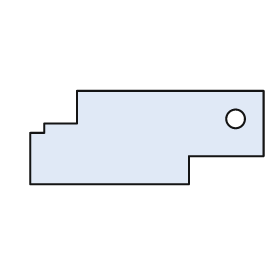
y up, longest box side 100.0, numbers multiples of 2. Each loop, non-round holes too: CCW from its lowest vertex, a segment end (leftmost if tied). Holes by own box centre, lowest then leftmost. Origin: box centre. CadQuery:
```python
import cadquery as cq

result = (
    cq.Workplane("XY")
    .moveTo(-50.0, -20.0)
    .lineTo(18.0, -20.0)
    .lineTo(18.0, -8.0)
    .lineTo(50.0, -8.0)
    .lineTo(50.0, 20.0)
    .lineTo(-30.0, 20.0)
    .lineTo(-30.0, 6.0)
    .lineTo(-44.0, 6.0)
    .lineTo(-44.0, 2.0)
    .lineTo(-50.0, 2.0)
    .close()
    .moveTo(38.0, 8.0)
    .circle(4.0)
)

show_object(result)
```